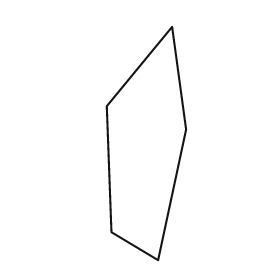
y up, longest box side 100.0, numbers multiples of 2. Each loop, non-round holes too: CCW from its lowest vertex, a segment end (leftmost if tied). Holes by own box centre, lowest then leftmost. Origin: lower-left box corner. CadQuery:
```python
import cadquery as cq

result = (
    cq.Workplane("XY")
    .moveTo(22.0, 0.0)
    .lineTo(34.0, 56.0)
    .lineTo(28.0, 100.0)
    .lineTo(0.0, 66.0)
    .lineTo(2.0, 12.0)
    .close()
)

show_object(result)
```